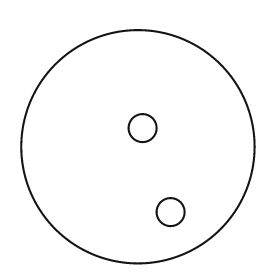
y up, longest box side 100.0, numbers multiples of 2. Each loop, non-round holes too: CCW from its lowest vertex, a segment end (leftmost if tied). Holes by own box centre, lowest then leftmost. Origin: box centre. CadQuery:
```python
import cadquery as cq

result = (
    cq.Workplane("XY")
    .moveTo(0.0, 0.0)
    .circle(50.0)
    .moveTo(14.0, -28.0)
    .circle(6.0)
    .moveTo(2.0, 8.0)
    .circle(6.0)
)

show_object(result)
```